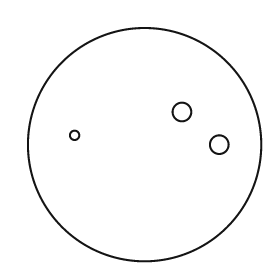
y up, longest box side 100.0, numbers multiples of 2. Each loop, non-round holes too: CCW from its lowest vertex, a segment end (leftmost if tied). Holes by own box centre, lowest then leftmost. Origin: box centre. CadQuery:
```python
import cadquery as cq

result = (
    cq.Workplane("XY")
    .moveTo(0.0, 0.0)
    .circle(50.0)
    .moveTo(32.0, 0.0)
    .circle(4.0)
    .moveTo(-30.0, 4.0)
    .circle(2.0)
    .moveTo(16.0, 14.0)
    .circle(4.0)
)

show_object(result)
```